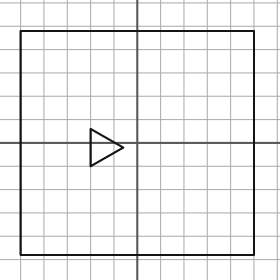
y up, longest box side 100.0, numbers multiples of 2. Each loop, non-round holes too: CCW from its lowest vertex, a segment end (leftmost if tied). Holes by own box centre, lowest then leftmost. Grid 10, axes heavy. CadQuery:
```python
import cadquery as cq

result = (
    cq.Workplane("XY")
    .moveTo(-50.0, -48.0)
    .lineTo(50.0, -48.0)
    .lineTo(50.0, 48.0)
    .lineTo(-50.0, 48.0)
    .close()
    .moveTo(-20.0, -10.0)
    .lineTo(-6.0, -2.0)
    .lineTo(-20.0, 6.0)
    .close()
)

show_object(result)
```